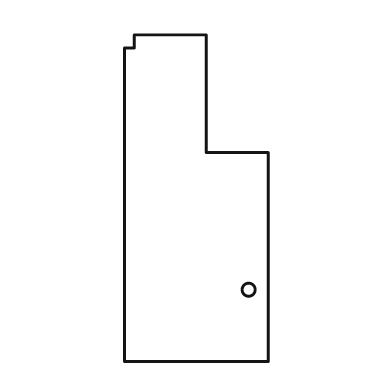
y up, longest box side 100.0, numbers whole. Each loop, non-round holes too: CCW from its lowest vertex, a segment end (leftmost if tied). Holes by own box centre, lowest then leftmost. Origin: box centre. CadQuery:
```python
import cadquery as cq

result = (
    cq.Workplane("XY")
    .moveTo(-22.0, -50.0)
    .lineTo(22.0, -50.0)
    .lineTo(22.0, 14.0)
    .lineTo(3.0, 14.0)
    .lineTo(3.0, 50.0)
    .lineTo(-19.0, 50.0)
    .lineTo(-19.0, 46.0)
    .lineTo(-22.0, 46.0)
    .close()
    .moveTo(16.0, -28.0)
    .circle(2.0)
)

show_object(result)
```